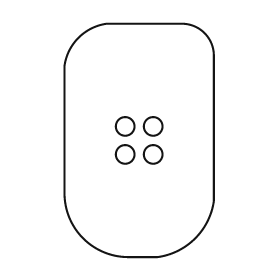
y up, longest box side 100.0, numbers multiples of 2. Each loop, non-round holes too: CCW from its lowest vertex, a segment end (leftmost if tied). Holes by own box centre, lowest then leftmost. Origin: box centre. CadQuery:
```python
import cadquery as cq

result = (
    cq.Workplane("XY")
    .moveTo(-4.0, -50.0)
    .lineTo(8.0, -50.0)
    .threePointArc((24.0, -42.0), (32.0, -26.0))
    .lineTo(32.0, 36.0)
    .threePointArc((28.0, 46.0), (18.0, 50.0))
    .lineTo(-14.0, 50.0)
    .threePointArc((-26.0, 44.0), (-32.0, 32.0))
    .lineTo(-32.0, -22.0)
    .threePointArc((-24.0, -42.0), (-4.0, -50.0))
    .close()
    .moveTo(-6.0, -6.0)
    .circle(4.0)
    .moveTo(6.0, -6.0)
    .circle(4.0)
    .moveTo(-6.0, 6.0)
    .circle(4.0)
    .moveTo(6.0, 6.0)
    .circle(4.0)
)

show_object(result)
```